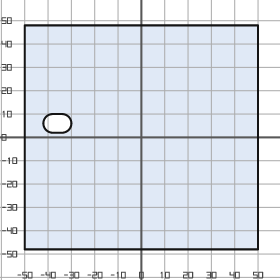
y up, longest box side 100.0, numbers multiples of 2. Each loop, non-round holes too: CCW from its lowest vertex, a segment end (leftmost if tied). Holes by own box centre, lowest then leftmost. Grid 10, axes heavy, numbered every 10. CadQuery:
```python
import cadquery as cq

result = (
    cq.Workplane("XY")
    .moveTo(-50.0, -48.0)
    .lineTo(50.0, -48.0)
    .lineTo(50.0, 48.0)
    .lineTo(-50.0, 48.0)
    .close()
    .moveTo(-38.0, 2.0)
    .lineTo(-34.0, 2.0)
    .threePointArc((-30.0, 6.0), (-34.0, 10.0))
    .lineTo(-38.0, 10.0)
    .threePointArc((-42.0, 6.0), (-38.0, 2.0))
    .close()
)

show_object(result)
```